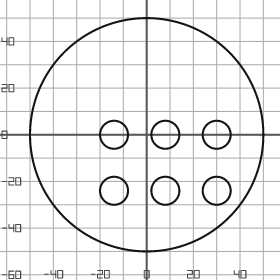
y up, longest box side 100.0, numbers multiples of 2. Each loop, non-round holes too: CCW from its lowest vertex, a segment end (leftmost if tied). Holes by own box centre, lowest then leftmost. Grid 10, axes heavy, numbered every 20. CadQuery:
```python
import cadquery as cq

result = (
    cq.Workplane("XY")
    .moveTo(0.0, 0.0)
    .circle(50.0)
    .moveTo(-14.0, -24.0)
    .circle(6.0)
    .moveTo(8.0, -24.0)
    .circle(6.0)
    .moveTo(30.0, -24.0)
    .circle(6.0)
    .moveTo(-14.0, 0.0)
    .circle(6.0)
    .moveTo(8.0, 0.0)
    .circle(6.0)
    .moveTo(30.0, 0.0)
    .circle(6.0)
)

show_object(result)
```